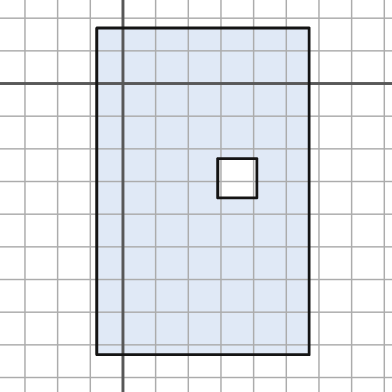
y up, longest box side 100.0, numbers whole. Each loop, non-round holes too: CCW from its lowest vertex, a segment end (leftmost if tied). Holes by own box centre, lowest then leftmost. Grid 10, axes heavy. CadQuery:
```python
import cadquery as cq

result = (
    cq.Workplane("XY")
    .moveTo(-8.0, -83.0)
    .lineTo(57.0, -83.0)
    .lineTo(57.0, 17.0)
    .lineTo(-8.0, 17.0)
    .close()
    .moveTo(29.0, -35.0)
    .lineTo(41.0, -35.0)
    .lineTo(41.0, -23.0)
    .lineTo(29.0, -23.0)
    .close()
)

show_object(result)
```